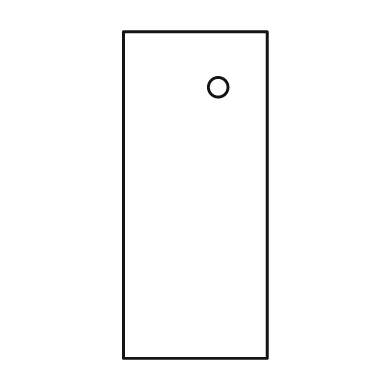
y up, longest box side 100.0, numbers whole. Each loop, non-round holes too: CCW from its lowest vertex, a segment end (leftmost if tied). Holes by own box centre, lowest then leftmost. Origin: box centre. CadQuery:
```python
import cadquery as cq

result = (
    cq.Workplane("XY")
    .moveTo(-22.0, -50.0)
    .lineTo(22.0, -50.0)
    .lineTo(22.0, 50.0)
    .lineTo(-22.0, 50.0)
    .close()
    .moveTo(7.0, 33.0)
    .circle(3.0)
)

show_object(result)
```